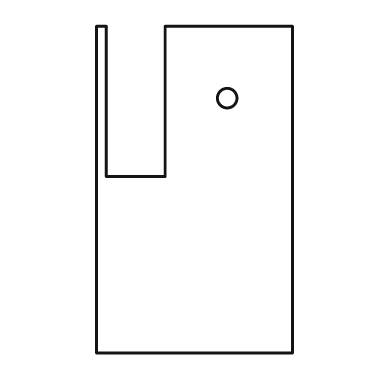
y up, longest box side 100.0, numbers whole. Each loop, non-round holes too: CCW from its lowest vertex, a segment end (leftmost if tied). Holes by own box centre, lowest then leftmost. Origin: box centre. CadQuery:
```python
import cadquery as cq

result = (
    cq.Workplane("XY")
    .moveTo(-30.0, -50.0)
    .lineTo(30.0, -50.0)
    .lineTo(30.0, 50.0)
    .lineTo(-9.0, 50.0)
    .lineTo(-9.0, 4.0)
    .lineTo(-27.0, 4.0)
    .lineTo(-27.0, 50.0)
    .lineTo(-30.0, 50.0)
    .close()
    .moveTo(10.0, 28.0)
    .circle(3.0)
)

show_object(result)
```